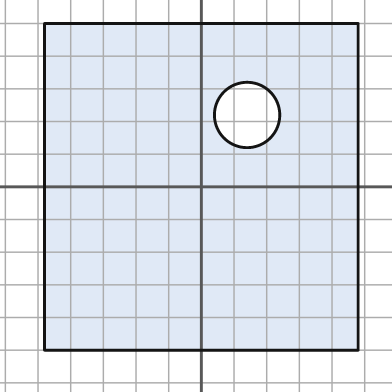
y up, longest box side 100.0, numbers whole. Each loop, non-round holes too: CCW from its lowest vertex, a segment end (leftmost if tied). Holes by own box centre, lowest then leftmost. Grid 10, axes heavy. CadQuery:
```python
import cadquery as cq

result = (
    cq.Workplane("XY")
    .moveTo(-48.0, -50.0)
    .lineTo(48.0, -50.0)
    .lineTo(48.0, 50.0)
    .lineTo(-48.0, 50.0)
    .close()
    .moveTo(14.0, 22.0)
    .circle(10.0)
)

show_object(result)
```